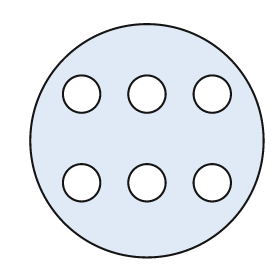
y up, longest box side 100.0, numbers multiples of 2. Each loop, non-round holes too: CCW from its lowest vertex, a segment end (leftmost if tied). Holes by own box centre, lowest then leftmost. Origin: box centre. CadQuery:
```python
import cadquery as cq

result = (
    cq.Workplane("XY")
    .moveTo(0.0, 0.0)
    .circle(50.0)
    .moveTo(-28.0, -18.0)
    .circle(8.0)
    .moveTo(0.0, -18.0)
    .circle(8.0)
    .moveTo(28.0, -18.0)
    .circle(8.0)
    .moveTo(-28.0, 20.0)
    .circle(8.0)
    .moveTo(0.0, 20.0)
    .circle(8.0)
    .moveTo(28.0, 20.0)
    .circle(8.0)
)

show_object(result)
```